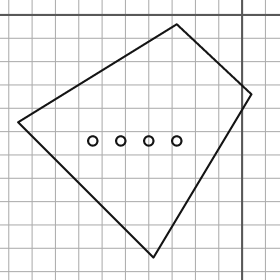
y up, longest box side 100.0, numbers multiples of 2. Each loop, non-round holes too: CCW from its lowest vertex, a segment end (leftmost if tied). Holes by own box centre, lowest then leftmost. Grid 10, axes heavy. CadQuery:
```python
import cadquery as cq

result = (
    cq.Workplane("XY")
    .moveTo(-38.0, -104.0)
    .lineTo(4.0, -34.0)
    .lineTo(-28.0, -4.0)
    .lineTo(-96.0, -46.0)
    .close()
    .moveTo(-64.0, -54.0)
    .circle(2.0)
    .moveTo(-52.0, -54.0)
    .circle(2.0)
    .moveTo(-40.0, -54.0)
    .circle(2.0)
    .moveTo(-28.0, -54.0)
    .circle(2.0)
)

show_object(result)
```